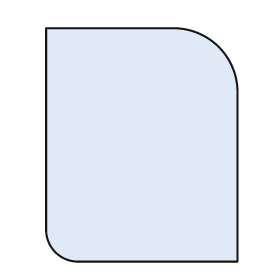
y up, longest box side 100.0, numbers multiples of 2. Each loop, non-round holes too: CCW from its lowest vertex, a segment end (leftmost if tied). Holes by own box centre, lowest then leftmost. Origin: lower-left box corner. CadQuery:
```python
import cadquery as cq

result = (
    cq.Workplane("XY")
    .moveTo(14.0, 0.0)
    .lineTo(82.0, 0.0)
    .lineTo(82.0, 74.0)
    .threePointArc((74.0, 92.0), (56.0, 100.0))
    .lineTo(0.0, 100.0)
    .lineTo(0.0, 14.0)
    .threePointArc((4.0, 4.0), (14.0, 0.0))
    .close()
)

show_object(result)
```